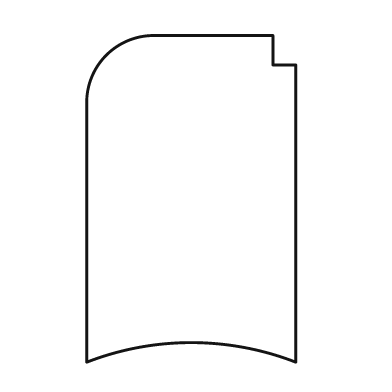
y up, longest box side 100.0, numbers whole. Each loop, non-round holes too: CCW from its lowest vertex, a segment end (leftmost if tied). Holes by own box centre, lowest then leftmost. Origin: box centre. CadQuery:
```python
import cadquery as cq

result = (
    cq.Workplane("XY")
    .moveTo(-32.0, -50.0)
    .threePointArc((0.0, -44.0), (32.0, -50.0))
    .lineTo(32.0, 41.0)
    .lineTo(25.0, 41.0)
    .lineTo(25.0, 50.0)
    .lineTo(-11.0, 50.0)
    .threePointArc((-26.0, 44.0), (-32.0, 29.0))
    .close()
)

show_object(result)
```